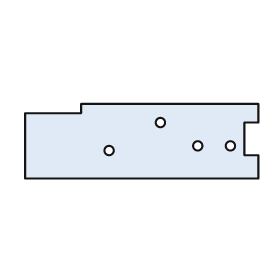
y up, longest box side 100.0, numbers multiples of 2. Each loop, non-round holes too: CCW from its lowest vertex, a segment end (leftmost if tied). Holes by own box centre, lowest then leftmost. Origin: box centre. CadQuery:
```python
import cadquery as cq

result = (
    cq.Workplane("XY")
    .moveTo(-50.0, -16.0)
    .lineTo(50.0, -16.0)
    .lineTo(50.0, -6.0)
    .lineTo(44.0, -6.0)
    .lineTo(44.0, 8.0)
    .lineTo(50.0, 8.0)
    .lineTo(50.0, 16.0)
    .lineTo(-26.0, 16.0)
    .lineTo(-26.0, 12.0)
    .lineTo(-50.0, 12.0)
    .close()
    .moveTo(-14.0, -4.0)
    .circle(2.0)
    .moveTo(24.0, -2.0)
    .circle(2.0)
    .moveTo(38.0, -2.0)
    .circle(2.0)
    .moveTo(8.0, 8.0)
    .circle(2.0)
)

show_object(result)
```